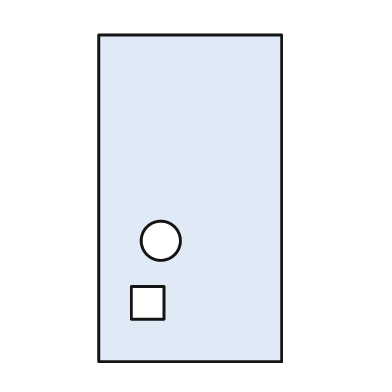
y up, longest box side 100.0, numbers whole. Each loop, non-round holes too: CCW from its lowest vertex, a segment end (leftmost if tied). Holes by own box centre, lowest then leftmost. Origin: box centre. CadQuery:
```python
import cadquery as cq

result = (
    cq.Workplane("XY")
    .moveTo(-28.0, -50.0)
    .lineTo(28.0, -50.0)
    .lineTo(28.0, 50.0)
    .lineTo(-28.0, 50.0)
    .close()
    .moveTo(-18.0, -37.0)
    .lineTo(-8.0, -37.0)
    .lineTo(-8.0, -27.0)
    .lineTo(-18.0, -27.0)
    .close()
    .moveTo(-9.0, -13.0)
    .circle(6.0)
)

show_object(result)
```